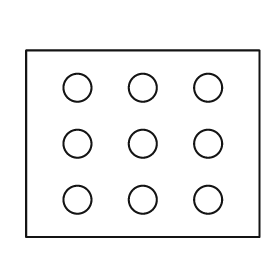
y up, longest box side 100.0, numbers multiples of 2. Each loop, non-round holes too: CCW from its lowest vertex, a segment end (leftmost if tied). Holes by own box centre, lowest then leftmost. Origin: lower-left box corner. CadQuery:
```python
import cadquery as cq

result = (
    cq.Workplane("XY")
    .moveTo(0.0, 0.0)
    .lineTo(100.0, 0.0)
    .lineTo(100.0, 80.0)
    .lineTo(0.0, 80.0)
    .close()
    .moveTo(22.0, 16.0)
    .circle(6.0)
    .moveTo(50.0, 16.0)
    .circle(6.0)
    .moveTo(78.0, 16.0)
    .circle(6.0)
    .moveTo(22.0, 40.0)
    .circle(6.0)
    .moveTo(50.0, 40.0)
    .circle(6.0)
    .moveTo(78.0, 40.0)
    .circle(6.0)
    .moveTo(22.0, 64.0)
    .circle(6.0)
    .moveTo(50.0, 64.0)
    .circle(6.0)
    .moveTo(78.0, 64.0)
    .circle(6.0)
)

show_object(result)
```